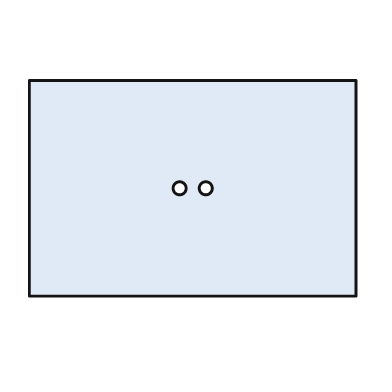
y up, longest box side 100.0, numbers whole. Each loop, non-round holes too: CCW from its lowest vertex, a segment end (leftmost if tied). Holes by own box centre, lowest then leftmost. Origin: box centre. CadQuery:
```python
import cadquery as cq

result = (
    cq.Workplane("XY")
    .moveTo(-50.0, -33.0)
    .lineTo(50.0, -33.0)
    .lineTo(50.0, 33.0)
    .lineTo(-50.0, 33.0)
    .close()
    .moveTo(-4.0, 0.0)
    .circle(2.0)
    .moveTo(4.0, 0.0)
    .circle(2.0)
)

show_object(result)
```